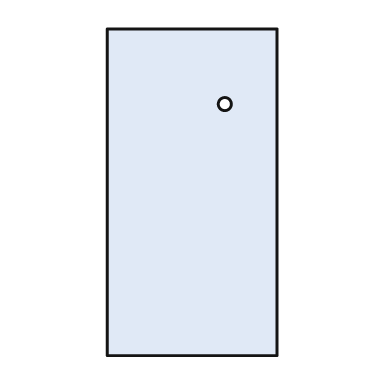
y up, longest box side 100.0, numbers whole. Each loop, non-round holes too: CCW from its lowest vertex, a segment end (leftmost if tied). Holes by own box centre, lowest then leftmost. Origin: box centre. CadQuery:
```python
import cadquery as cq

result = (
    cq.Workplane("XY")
    .moveTo(-26.0, -50.0)
    .lineTo(26.0, -50.0)
    .lineTo(26.0, 50.0)
    .lineTo(-26.0, 50.0)
    .close()
    .moveTo(10.0, 27.0)
    .circle(2.0)
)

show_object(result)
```